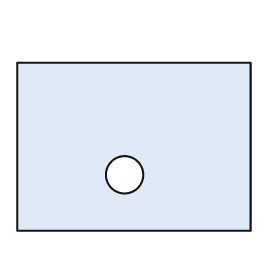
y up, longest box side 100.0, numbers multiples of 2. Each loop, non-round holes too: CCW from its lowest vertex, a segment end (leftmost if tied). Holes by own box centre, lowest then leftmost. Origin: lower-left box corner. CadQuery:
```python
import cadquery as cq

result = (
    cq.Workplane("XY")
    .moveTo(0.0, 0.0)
    .lineTo(100.0, 0.0)
    .lineTo(100.0, 72.0)
    .lineTo(0.0, 72.0)
    .close()
    .moveTo(46.0, 24.0)
    .circle(8.0)
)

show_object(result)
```